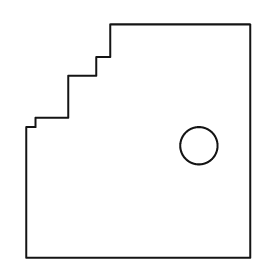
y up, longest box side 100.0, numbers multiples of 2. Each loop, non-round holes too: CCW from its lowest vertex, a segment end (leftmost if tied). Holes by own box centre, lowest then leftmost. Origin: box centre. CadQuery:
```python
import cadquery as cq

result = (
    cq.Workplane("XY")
    .moveTo(-48.0, -50.0)
    .lineTo(48.0, -50.0)
    .lineTo(48.0, 50.0)
    .lineTo(-12.0, 50.0)
    .lineTo(-12.0, 36.0)
    .lineTo(-18.0, 36.0)
    .lineTo(-18.0, 28.0)
    .lineTo(-30.0, 28.0)
    .lineTo(-30.0, 10.0)
    .lineTo(-44.0, 10.0)
    .lineTo(-44.0, 6.0)
    .lineTo(-48.0, 6.0)
    .close()
    .moveTo(26.0, -2.0)
    .circle(8.0)
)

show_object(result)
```